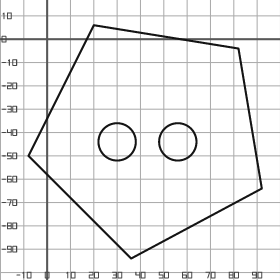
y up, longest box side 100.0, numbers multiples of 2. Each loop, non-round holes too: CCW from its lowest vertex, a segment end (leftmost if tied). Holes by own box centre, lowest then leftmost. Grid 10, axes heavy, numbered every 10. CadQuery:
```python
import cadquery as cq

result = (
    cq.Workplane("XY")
    .moveTo(36.0, -94.0)
    .lineTo(92.0, -64.0)
    .lineTo(82.0, -4.0)
    .lineTo(20.0, 6.0)
    .lineTo(-8.0, -50.0)
    .close()
    .moveTo(30.0, -44.0)
    .circle(8.0)
    .moveTo(56.0, -44.0)
    .circle(8.0)
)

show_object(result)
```